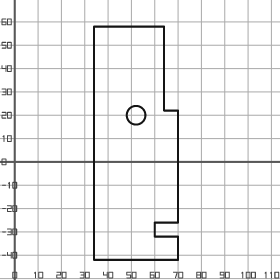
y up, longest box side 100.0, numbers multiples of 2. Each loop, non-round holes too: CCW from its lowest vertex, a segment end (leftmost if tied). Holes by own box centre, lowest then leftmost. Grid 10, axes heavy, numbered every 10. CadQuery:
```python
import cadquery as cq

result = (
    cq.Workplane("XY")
    .moveTo(34.0, -42.0)
    .lineTo(70.0, -42.0)
    .lineTo(70.0, -32.0)
    .lineTo(60.0, -32.0)
    .lineTo(60.0, -26.0)
    .lineTo(70.0, -26.0)
    .lineTo(70.0, 22.0)
    .lineTo(64.0, 22.0)
    .lineTo(64.0, 58.0)
    .lineTo(34.0, 58.0)
    .close()
    .moveTo(52.0, 20.0)
    .circle(4.0)
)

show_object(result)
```